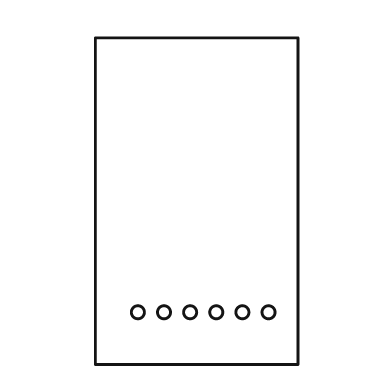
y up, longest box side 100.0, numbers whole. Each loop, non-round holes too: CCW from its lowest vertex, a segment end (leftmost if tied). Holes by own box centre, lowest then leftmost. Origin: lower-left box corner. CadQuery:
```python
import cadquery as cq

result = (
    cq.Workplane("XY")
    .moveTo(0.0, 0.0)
    .lineTo(62.0, 0.0)
    .lineTo(62.0, 100.0)
    .lineTo(0.0, 100.0)
    .close()
    .moveTo(13.0, 16.0)
    .circle(2.0)
    .moveTo(21.0, 16.0)
    .circle(2.0)
    .moveTo(29.0, 16.0)
    .circle(2.0)
    .moveTo(37.0, 16.0)
    .circle(2.0)
    .moveTo(45.0, 16.0)
    .circle(2.0)
    .moveTo(53.0, 16.0)
    .circle(2.0)
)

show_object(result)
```